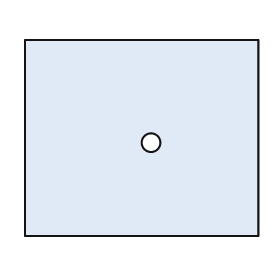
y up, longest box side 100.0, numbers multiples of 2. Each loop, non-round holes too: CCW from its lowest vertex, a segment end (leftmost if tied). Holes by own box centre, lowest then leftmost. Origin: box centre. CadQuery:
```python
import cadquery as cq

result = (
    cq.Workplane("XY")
    .moveTo(-50.0, -42.0)
    .lineTo(50.0, -42.0)
    .lineTo(50.0, 42.0)
    .lineTo(-50.0, 42.0)
    .close()
    .moveTo(4.0, -2.0)
    .circle(4.0)
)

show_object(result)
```